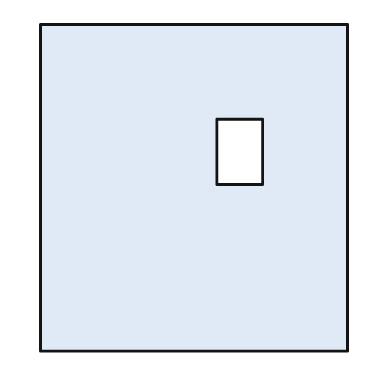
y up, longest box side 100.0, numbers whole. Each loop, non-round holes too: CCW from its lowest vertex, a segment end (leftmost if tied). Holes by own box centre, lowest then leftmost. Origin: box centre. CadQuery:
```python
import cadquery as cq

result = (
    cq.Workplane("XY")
    .moveTo(-47.0, -50.0)
    .lineTo(47.0, -50.0)
    .lineTo(47.0, 50.0)
    .lineTo(-47.0, 50.0)
    .close()
    .moveTo(7.0, 1.0)
    .lineTo(21.0, 1.0)
    .lineTo(21.0, 21.0)
    .lineTo(7.0, 21.0)
    .close()
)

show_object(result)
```